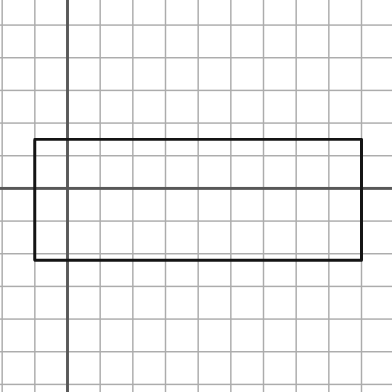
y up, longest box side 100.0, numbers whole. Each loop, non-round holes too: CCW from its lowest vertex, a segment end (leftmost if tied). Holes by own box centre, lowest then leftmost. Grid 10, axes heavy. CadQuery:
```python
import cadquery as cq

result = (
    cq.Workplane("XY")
    .moveTo(-10.0, -22.0)
    .lineTo(90.0, -22.0)
    .lineTo(90.0, 15.0)
    .lineTo(-10.0, 15.0)
    .close()
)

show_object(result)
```